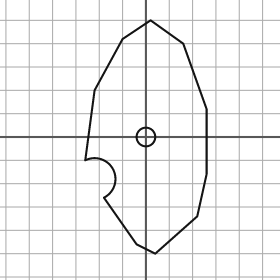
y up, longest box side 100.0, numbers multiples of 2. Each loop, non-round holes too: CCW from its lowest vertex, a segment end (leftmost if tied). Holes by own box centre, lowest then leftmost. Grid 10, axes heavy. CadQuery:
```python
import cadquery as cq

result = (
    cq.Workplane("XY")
    .moveTo(4.0, -50.0)
    .lineTo(22.0, -34.0)
    .lineTo(26.0, -16.0)
    .lineTo(26.0, 12.0)
    .lineTo(16.0, 40.0)
    .lineTo(2.0, 50.0)
    .lineTo(-10.0, 42.0)
    .lineTo(-22.0, 20.0)
    .lineTo(-26.0, -10.0)
    .threePointArc((-14.0, -14.0), (-18.0, -26.0))
    .lineTo(-4.0, -46.0)
    .close()
    .moveTo(0.0, 0.0)
    .circle(4.0)
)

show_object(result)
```